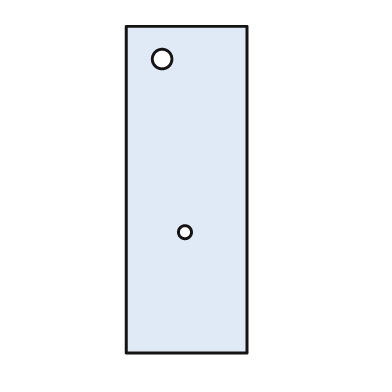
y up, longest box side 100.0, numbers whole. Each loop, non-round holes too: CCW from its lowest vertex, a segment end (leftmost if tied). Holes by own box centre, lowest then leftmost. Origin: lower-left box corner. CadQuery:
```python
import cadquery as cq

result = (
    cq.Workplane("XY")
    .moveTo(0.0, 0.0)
    .lineTo(37.0, 0.0)
    .lineTo(37.0, 100.0)
    .lineTo(0.0, 100.0)
    .close()
    .moveTo(18.0, 37.0)
    .circle(2.0)
    .moveTo(11.0, 90.0)
    .circle(3.0)
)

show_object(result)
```